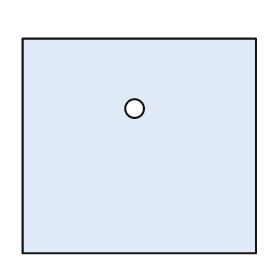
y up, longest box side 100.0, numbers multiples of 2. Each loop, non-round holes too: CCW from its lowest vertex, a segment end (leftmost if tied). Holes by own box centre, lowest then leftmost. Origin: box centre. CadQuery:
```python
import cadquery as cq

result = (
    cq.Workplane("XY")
    .moveTo(-50.0, -46.0)
    .lineTo(50.0, -46.0)
    .lineTo(50.0, 46.0)
    .lineTo(-50.0, 46.0)
    .close()
    .moveTo(-2.0, 16.0)
    .circle(4.0)
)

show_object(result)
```